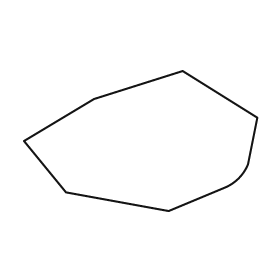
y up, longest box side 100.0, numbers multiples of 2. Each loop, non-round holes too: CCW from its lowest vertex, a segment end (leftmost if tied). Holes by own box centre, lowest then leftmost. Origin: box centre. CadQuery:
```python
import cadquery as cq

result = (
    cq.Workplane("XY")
    .moveTo(12.0, -30.0)
    .lineTo(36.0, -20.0)
    .threePointArc((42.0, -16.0), (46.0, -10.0))
    .lineTo(50.0, 10.0)
    .lineTo(18.0, 30.0)
    .lineTo(-20.0, 18.0)
    .lineTo(-50.0, 0.0)
    .lineTo(-32.0, -22.0)
    .close()
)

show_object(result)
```